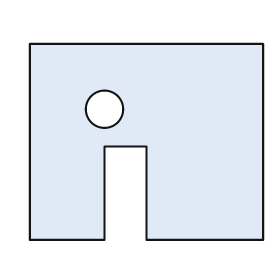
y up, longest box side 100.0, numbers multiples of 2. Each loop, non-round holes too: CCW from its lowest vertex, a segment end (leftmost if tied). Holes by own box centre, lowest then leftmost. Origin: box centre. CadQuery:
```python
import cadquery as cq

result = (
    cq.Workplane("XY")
    .moveTo(-50.0, -42.0)
    .lineTo(-18.0, -42.0)
    .lineTo(-18.0, -2.0)
    .lineTo(0.0, -2.0)
    .lineTo(0.0, -42.0)
    .lineTo(50.0, -42.0)
    .lineTo(50.0, 42.0)
    .lineTo(-50.0, 42.0)
    .close()
    .moveTo(-18.0, 14.0)
    .circle(8.0)
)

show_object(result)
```